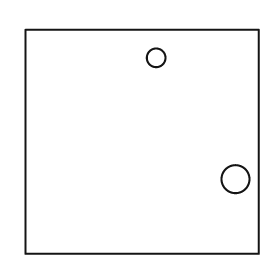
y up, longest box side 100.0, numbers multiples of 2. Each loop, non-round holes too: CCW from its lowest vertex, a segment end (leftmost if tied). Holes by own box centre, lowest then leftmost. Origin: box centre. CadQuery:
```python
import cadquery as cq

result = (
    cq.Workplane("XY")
    .moveTo(-50.0, -48.0)
    .lineTo(50.0, -48.0)
    .lineTo(50.0, 48.0)
    .lineTo(-50.0, 48.0)
    .close()
    .moveTo(40.0, -16.0)
    .circle(6.0)
    .moveTo(6.0, 36.0)
    .circle(4.0)
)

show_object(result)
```